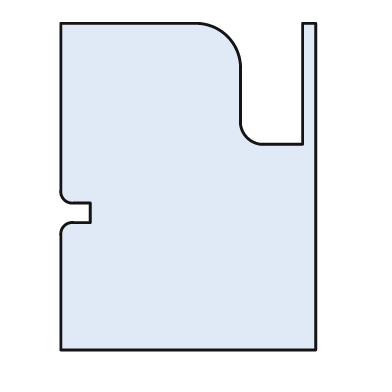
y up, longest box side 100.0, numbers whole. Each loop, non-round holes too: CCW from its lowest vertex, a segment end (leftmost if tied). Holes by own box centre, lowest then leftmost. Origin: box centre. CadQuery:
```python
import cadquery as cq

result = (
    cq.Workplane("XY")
    .moveTo(-39.0, -50.0)
    .lineTo(39.0, -50.0)
    .lineTo(39.0, 50.0)
    .lineTo(35.0, 50.0)
    .lineTo(35.0, 13.0)
    .lineTo(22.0, 13.0)
    .threePointArc((18.0, 15.0), (16.0, 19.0))
    .lineTo(16.0, 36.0)
    .threePointArc((12.0, 46.0), (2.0, 50.0))
    .lineTo(-39.0, 50.0)
    .lineTo(-39.0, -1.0)
    .threePointArc((-38.0, -4.0), (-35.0, -5.0))
    .lineTo(-30.0, -5.0)
    .lineTo(-30.0, -11.0)
    .lineTo(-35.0, -11.0)
    .threePointArc((-38.0, -12.0), (-39.0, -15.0))
    .close()
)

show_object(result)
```